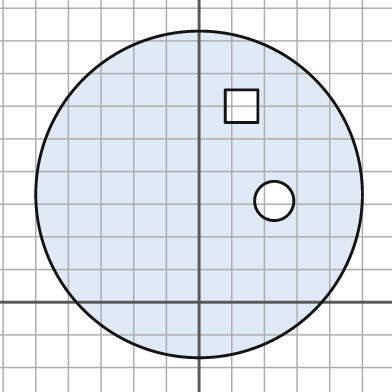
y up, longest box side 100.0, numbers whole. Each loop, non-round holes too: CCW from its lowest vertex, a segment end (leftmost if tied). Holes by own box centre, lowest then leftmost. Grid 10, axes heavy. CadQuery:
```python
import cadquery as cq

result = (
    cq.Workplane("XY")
    .moveTo(0.0, 33.0)
    .circle(50.0)
    .moveTo(23.0, 31.0)
    .circle(6.0)
    .moveTo(8.0, 55.0)
    .lineTo(18.0, 55.0)
    .lineTo(18.0, 65.0)
    .lineTo(8.0, 65.0)
    .close()
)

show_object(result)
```